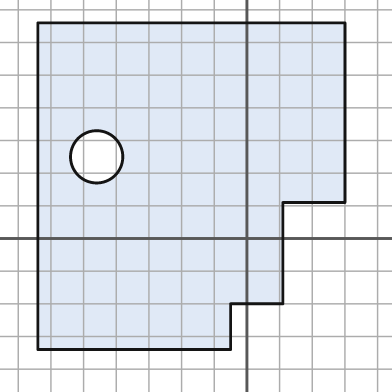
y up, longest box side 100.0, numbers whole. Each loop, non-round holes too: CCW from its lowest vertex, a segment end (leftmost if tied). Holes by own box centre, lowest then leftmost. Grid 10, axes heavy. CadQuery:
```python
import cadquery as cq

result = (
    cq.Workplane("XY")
    .moveTo(-64.0, -34.0)
    .lineTo(-5.0, -34.0)
    .lineTo(-5.0, -20.0)
    .lineTo(11.0, -20.0)
    .lineTo(11.0, 11.0)
    .lineTo(30.0, 11.0)
    .lineTo(30.0, 66.0)
    .lineTo(-64.0, 66.0)
    .close()
    .moveTo(-46.0, 25.0)
    .circle(8.0)
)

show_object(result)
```